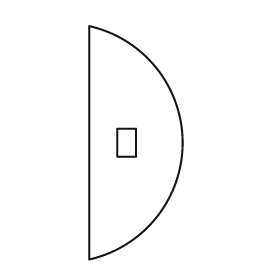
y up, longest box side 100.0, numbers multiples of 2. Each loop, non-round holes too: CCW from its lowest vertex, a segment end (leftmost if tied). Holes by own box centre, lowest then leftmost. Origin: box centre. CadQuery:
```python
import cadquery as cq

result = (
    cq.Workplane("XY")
    .moveTo(-20.0, -50.0)
    .threePointArc((20.0, 0.0), (-20.0, 50.0))
    .close()
    .moveTo(-8.0, -6.0)
    .lineTo(0.0, -6.0)
    .lineTo(0.0, 6.0)
    .lineTo(-8.0, 6.0)
    .close()
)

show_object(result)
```